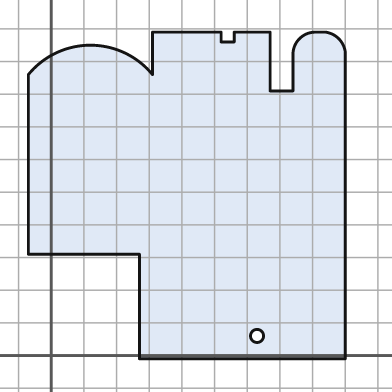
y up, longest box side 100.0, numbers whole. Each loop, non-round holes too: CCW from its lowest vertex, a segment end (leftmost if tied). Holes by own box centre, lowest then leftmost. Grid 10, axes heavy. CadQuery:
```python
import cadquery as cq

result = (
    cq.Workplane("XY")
    .moveTo(27.0, -1.0)
    .lineTo(90.0, -1.0)
    .lineTo(90.0, 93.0)
    .threePointArc((88.0, 97.0), (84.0, 99.0))
    .lineTo(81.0, 99.0)
    .threePointArc((76.0, 97.0), (74.0, 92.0))
    .lineTo(74.0, 81.0)
    .lineTo(67.0, 81.0)
    .lineTo(67.0, 99.0)
    .lineTo(56.0, 99.0)
    .lineTo(56.0, 96.0)
    .lineTo(52.0, 96.0)
    .lineTo(52.0, 99.0)
    .lineTo(31.0, 99.0)
    .lineTo(31.0, 86.0)
    .threePointArc((12.0, 95.0), (-7.0, 86.0))
    .lineTo(-7.0, 31.0)
    .lineTo(27.0, 31.0)
    .close()
    .moveTo(63.0, 6.0)
    .circle(2.0)
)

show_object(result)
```